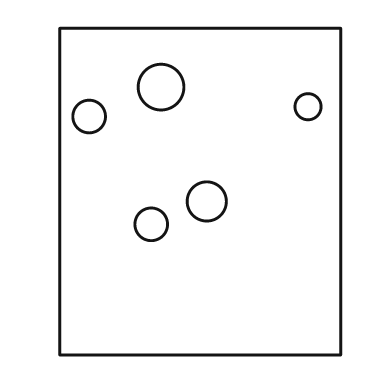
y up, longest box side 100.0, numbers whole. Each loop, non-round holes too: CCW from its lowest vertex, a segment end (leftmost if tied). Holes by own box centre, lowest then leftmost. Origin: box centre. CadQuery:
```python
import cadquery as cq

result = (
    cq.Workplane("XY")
    .moveTo(-43.0, -50.0)
    .lineTo(43.0, -50.0)
    .lineTo(43.0, 50.0)
    .lineTo(-43.0, 50.0)
    .close()
    .moveTo(-15.0, -10.0)
    .circle(5.0)
    .moveTo(2.0, -3.0)
    .circle(6.0)
    .moveTo(-34.0, 23.0)
    .circle(5.0)
    .moveTo(33.0, 26.0)
    .circle(4.0)
    .moveTo(-12.0, 32.0)
    .circle(7.0)
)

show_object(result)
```